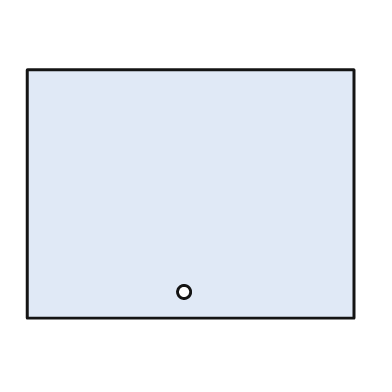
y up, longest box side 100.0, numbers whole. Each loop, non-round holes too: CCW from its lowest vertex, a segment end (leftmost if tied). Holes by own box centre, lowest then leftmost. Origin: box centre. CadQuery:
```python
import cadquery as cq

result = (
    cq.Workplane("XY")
    .moveTo(-50.0, -38.0)
    .lineTo(50.0, -38.0)
    .lineTo(50.0, 38.0)
    .lineTo(-50.0, 38.0)
    .close()
    .moveTo(-2.0, -30.0)
    .circle(2.0)
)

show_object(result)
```